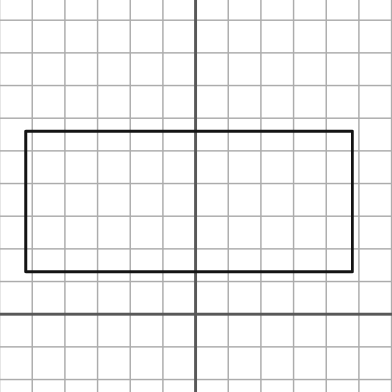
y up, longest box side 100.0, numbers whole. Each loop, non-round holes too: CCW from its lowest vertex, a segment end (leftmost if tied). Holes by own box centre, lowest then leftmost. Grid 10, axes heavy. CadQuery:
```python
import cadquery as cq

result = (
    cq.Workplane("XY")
    .moveTo(-52.0, 13.0)
    .lineTo(48.0, 13.0)
    .lineTo(48.0, 56.0)
    .lineTo(-52.0, 56.0)
    .close()
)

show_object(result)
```